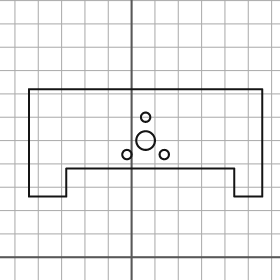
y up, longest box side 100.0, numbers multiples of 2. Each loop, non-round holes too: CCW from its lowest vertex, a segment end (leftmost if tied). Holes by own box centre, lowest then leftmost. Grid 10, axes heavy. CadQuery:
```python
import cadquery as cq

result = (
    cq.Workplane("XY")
    .moveTo(-44.0, 26.0)
    .lineTo(-28.0, 26.0)
    .lineTo(-28.0, 38.0)
    .lineTo(44.0, 38.0)
    .lineTo(44.0, 26.0)
    .lineTo(56.0, 26.0)
    .lineTo(56.0, 72.0)
    .lineTo(-44.0, 72.0)
    .close()
    .moveTo(-2.0, 44.0)
    .circle(2.0)
    .moveTo(14.0, 44.0)
    .circle(2.0)
    .moveTo(6.0, 50.0)
    .circle(4.0)
    .moveTo(6.0, 60.0)
    .circle(2.0)
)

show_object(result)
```